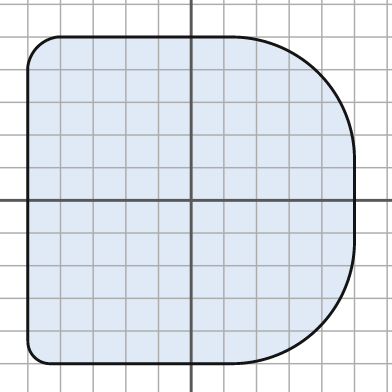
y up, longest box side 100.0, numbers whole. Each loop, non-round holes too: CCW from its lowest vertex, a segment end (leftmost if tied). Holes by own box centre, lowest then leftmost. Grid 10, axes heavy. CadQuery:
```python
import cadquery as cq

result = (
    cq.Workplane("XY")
    .moveTo(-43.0, -50.0)
    .lineTo(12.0, -50.0)
    .threePointArc((39.0, -39.0), (50.0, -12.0))
    .lineTo(50.0, 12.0)
    .threePointArc((39.0, 39.0), (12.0, 50.0))
    .lineTo(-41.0, 50.0)
    .threePointArc((-47.0, 47.0), (-50.0, 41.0))
    .lineTo(-50.0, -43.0)
    .threePointArc((-48.0, -48.0), (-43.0, -50.0))
    .close()
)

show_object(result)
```